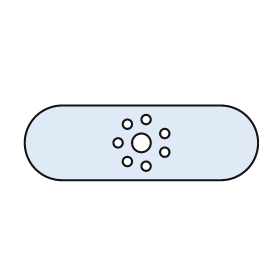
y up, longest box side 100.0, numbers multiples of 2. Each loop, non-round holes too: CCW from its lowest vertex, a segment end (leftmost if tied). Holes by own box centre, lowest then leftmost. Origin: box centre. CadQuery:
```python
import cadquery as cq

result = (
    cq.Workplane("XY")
    .moveTo(-34.0, -16.0)
    .lineTo(34.0, -16.0)
    .threePointArc((50.0, 0.0), (34.0, 16.0))
    .lineTo(-34.0, 16.0)
    .threePointArc((-50.0, 0.0), (-34.0, -16.0))
    .close()
    .moveTo(2.0, -10.0)
    .circle(2.0)
    .moveTo(-6.0, -8.0)
    .circle(2.0)
    .moveTo(10.0, -4.0)
    .circle(2.0)
    .moveTo(-10.0, 0.0)
    .circle(2.0)
    .moveTo(0.0, 0.0)
    .circle(4.0)
    .moveTo(10.0, 4.0)
    .circle(2.0)
    .moveTo(-6.0, 8.0)
    .circle(2.0)
    .moveTo(2.0, 10.0)
    .circle(2.0)
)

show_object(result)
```